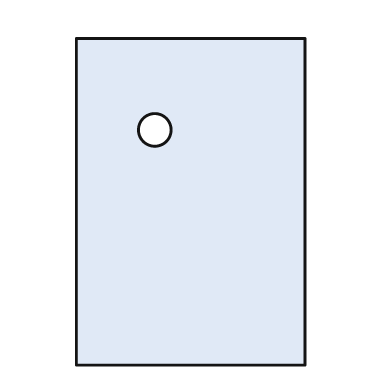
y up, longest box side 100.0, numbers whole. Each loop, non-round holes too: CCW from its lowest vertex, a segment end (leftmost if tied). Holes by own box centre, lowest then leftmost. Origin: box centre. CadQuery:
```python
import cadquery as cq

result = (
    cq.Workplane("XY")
    .moveTo(-35.0, -50.0)
    .lineTo(35.0, -50.0)
    .lineTo(35.0, 50.0)
    .lineTo(-35.0, 50.0)
    .close()
    .moveTo(-11.0, 22.0)
    .circle(5.0)
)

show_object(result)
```